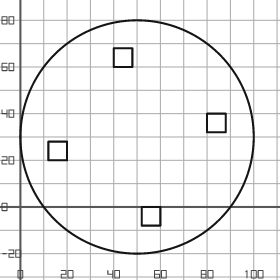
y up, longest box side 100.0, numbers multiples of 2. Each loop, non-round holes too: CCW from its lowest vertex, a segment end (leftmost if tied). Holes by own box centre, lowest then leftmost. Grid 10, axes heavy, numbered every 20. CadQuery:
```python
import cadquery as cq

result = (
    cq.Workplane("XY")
    .moveTo(50.0, 30.0)
    .circle(50.0)
    .moveTo(52.0, -8.0)
    .lineTo(60.0, -8.0)
    .lineTo(60.0, 0.0)
    .lineTo(52.0, 0.0)
    .close()
    .moveTo(12.0, 20.0)
    .lineTo(20.0, 20.0)
    .lineTo(20.0, 28.0)
    .lineTo(12.0, 28.0)
    .close()
    .moveTo(80.0, 32.0)
    .lineTo(88.0, 32.0)
    .lineTo(88.0, 40.0)
    .lineTo(80.0, 40.0)
    .close()
    .moveTo(40.0, 60.0)
    .lineTo(48.0, 60.0)
    .lineTo(48.0, 68.0)
    .lineTo(40.0, 68.0)
    .close()
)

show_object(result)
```